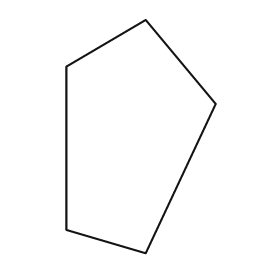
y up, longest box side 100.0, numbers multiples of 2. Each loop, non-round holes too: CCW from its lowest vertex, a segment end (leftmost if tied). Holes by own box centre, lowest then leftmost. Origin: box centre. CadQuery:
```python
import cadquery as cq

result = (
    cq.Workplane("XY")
    .moveTo(2.0, -50.0)
    .lineTo(32.0, 14.0)
    .lineTo(2.0, 50.0)
    .lineTo(-32.0, 30.0)
    .lineTo(-32.0, -40.0)
    .close()
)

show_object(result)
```